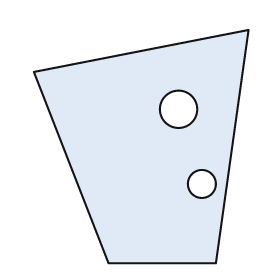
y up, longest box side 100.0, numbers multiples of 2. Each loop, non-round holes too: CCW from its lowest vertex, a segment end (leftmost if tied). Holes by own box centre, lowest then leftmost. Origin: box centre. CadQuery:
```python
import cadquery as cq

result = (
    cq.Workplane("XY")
    .moveTo(-14.0, -50.0)
    .lineTo(32.0, -50.0)
    .lineTo(46.0, 50.0)
    .lineTo(-46.0, 32.0)
    .close()
    .moveTo(26.0, -16.0)
    .circle(6.0)
    .moveTo(16.0, 16.0)
    .circle(8.0)
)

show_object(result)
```